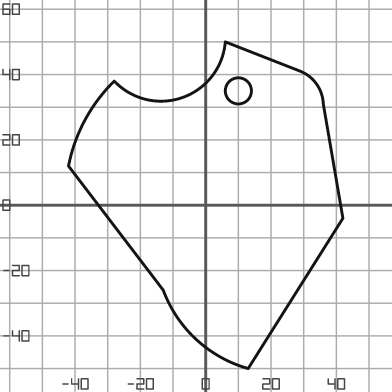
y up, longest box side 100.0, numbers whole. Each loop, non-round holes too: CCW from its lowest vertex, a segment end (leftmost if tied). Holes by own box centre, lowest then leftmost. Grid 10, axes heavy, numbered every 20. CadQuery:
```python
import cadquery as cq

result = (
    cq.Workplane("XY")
    .moveTo(13.0, -50.0)
    .lineTo(42.0, -4.0)
    .lineTo(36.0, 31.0)
    .threePointArc((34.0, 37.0), (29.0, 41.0))
    .lineTo(6.0, 50.0)
    .threePointArc((-7.0, 33.0), (-28.0, 38.0))
    .threePointArc((-37.0, 26.0), (-42.0, 12.0))
    .lineTo(-13.0, -26.0)
    .threePointArc((-3.0, -41.0), (13.0, -50.0))
    .close()
    .moveTo(10.0, 35.0)
    .circle(4.0)
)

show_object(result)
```